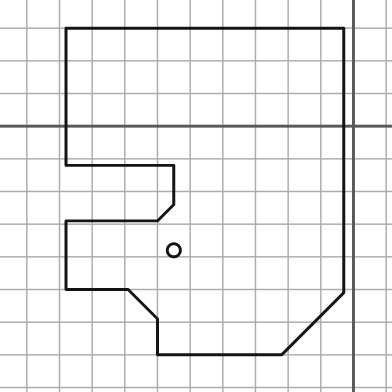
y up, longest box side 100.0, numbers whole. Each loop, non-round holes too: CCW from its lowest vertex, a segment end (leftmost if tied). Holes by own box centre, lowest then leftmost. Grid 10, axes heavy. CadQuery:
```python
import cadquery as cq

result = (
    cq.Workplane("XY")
    .moveTo(-60.0, -70.0)
    .lineTo(-22.0, -70.0)
    .lineTo(-3.0, -51.0)
    .lineTo(-3.0, 30.0)
    .lineTo(-88.0, 30.0)
    .lineTo(-88.0, -12.0)
    .lineTo(-55.0, -12.0)
    .lineTo(-55.0, -24.0)
    .lineTo(-60.0, -29.0)
    .lineTo(-88.0, -29.0)
    .lineTo(-88.0, -50.0)
    .lineTo(-69.0, -50.0)
    .lineTo(-60.0, -59.0)
    .close()
    .moveTo(-55.0, -38.0)
    .circle(2.0)
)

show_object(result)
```